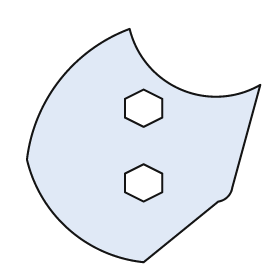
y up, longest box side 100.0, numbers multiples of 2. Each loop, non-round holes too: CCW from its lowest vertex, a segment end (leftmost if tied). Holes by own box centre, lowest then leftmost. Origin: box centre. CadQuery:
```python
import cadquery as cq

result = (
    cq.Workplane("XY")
    .moveTo(0.0, -50.0)
    .lineTo(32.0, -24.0)
    .threePointArc((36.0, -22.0), (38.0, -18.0))
    .lineTo(50.0, 26.0)
    .threePointArc((16.0, 24.0), (-6.0, 50.0))
    .threePointArc((-36.0, 28.0), (-50.0, -6.0))
    .threePointArc((-32.0, -36.0), (0.0, -50.0))
    .close()
    .moveTo(0.0, -24.0)
    .lineTo(8.0, -20.0)
    .lineTo(8.0, -12.0)
    .lineTo(0.0, -8.0)
    .lineTo(-8.0, -12.0)
    .lineTo(-8.0, -20.0)
    .close()
    .moveTo(0.0, 8.0)
    .lineTo(8.0, 12.0)
    .lineTo(8.0, 20.0)
    .lineTo(0.0, 24.0)
    .lineTo(-8.0, 20.0)
    .lineTo(-8.0, 12.0)
    .close()
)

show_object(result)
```